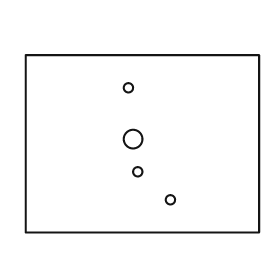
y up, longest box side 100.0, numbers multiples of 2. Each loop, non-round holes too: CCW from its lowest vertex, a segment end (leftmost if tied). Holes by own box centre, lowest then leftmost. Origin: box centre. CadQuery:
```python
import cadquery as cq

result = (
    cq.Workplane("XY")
    .moveTo(-50.0, -38.0)
    .lineTo(50.0, -38.0)
    .lineTo(50.0, 38.0)
    .lineTo(-50.0, 38.0)
    .close()
    .moveTo(12.0, -24.0)
    .circle(2.0)
    .moveTo(-2.0, -12.0)
    .circle(2.0)
    .moveTo(-4.0, 2.0)
    .circle(4.0)
    .moveTo(-6.0, 24.0)
    .circle(2.0)
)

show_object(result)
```